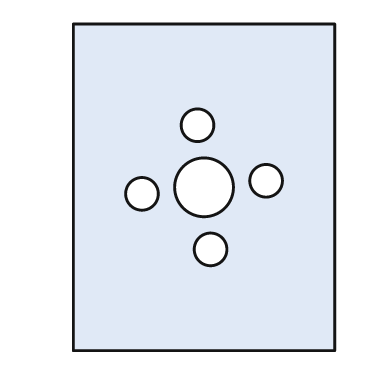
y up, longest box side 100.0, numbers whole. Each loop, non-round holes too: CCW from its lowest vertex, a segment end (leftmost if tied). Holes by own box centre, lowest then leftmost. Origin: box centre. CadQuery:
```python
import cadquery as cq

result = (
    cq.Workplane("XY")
    .moveTo(-40.0, -50.0)
    .lineTo(40.0, -50.0)
    .lineTo(40.0, 50.0)
    .lineTo(-40.0, 50.0)
    .close()
    .moveTo(2.0, -19.0)
    .circle(5.0)
    .moveTo(-19.0, -2.0)
    .circle(5.0)
    .moveTo(0.0, 0.0)
    .circle(9.0)
    .moveTo(19.0, 2.0)
    .circle(5.0)
    .moveTo(-2.0, 19.0)
    .circle(5.0)
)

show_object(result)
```